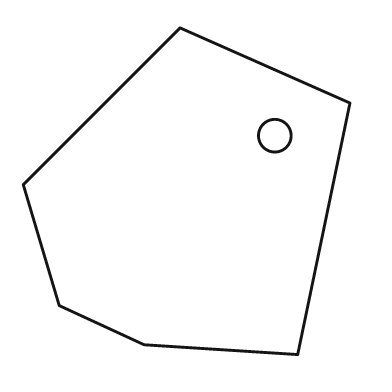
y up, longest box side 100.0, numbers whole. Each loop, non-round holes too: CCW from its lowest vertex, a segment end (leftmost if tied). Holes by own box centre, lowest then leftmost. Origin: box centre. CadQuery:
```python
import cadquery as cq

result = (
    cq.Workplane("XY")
    .moveTo(34.0, -50.0)
    .lineTo(50.0, 27.0)
    .lineTo(-2.0, 50.0)
    .lineTo(-50.0, 2.0)
    .lineTo(-39.0, -35.0)
    .lineTo(-13.0, -47.0)
    .close()
    .moveTo(27.0, 17.0)
    .circle(5.0)
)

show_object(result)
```